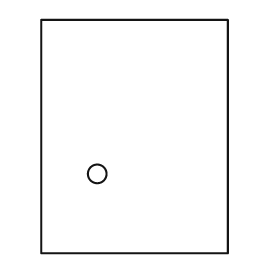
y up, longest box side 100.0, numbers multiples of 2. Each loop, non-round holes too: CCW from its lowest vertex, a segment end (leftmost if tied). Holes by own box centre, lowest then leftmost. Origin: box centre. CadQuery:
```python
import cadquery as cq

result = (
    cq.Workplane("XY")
    .moveTo(-40.0, -50.0)
    .lineTo(40.0, -50.0)
    .lineTo(40.0, 50.0)
    .lineTo(-40.0, 50.0)
    .close()
    .moveTo(-16.0, -16.0)
    .circle(4.0)
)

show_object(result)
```